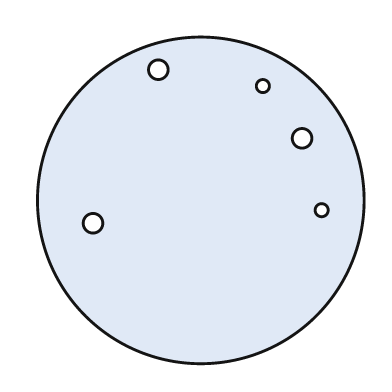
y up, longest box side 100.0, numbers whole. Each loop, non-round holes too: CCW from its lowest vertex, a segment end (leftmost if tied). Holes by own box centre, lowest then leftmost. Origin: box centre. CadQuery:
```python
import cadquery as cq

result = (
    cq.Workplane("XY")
    .moveTo(0.0, 0.0)
    .circle(50.0)
    .moveTo(-33.0, -7.0)
    .circle(3.0)
    .moveTo(37.0, -3.0)
    .circle(2.0)
    .moveTo(31.0, 19.0)
    .circle(3.0)
    .moveTo(19.0, 35.0)
    .circle(2.0)
    .moveTo(-13.0, 40.0)
    .circle(3.0)
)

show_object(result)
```